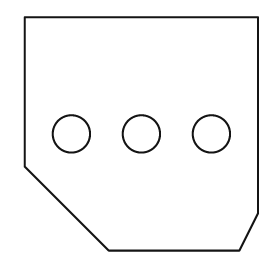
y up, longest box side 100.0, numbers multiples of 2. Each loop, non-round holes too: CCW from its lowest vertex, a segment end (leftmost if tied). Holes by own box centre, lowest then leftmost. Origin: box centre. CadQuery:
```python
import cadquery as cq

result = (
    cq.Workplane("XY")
    .moveTo(-14.0, -50.0)
    .lineTo(42.0, -50.0)
    .lineTo(50.0, -34.0)
    .lineTo(50.0, 50.0)
    .lineTo(-50.0, 50.0)
    .lineTo(-50.0, -14.0)
    .close()
    .moveTo(-30.0, 0.0)
    .circle(8.0)
    .moveTo(0.0, 0.0)
    .circle(8.0)
    .moveTo(30.0, 0.0)
    .circle(8.0)
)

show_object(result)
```